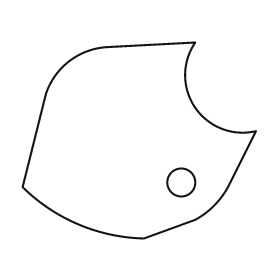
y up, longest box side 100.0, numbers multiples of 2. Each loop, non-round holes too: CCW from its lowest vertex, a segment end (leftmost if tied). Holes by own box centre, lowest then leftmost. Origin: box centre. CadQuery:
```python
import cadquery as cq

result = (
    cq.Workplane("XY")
    .moveTo(2.0, -42.0)
    .lineTo(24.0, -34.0)
    .threePointArc((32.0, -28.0), (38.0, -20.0))
    .lineTo(50.0, 4.0)
    .threePointArc((24.0, 14.0), (24.0, 42.0))
    .lineTo(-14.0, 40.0)
    .threePointArc((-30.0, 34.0), (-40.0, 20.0))
    .lineTo(-50.0, -20.0)
    .threePointArc((-26.0, -36.0), (2.0, -42.0))
    .close()
    .moveTo(18.0, -18.0)
    .circle(6.0)
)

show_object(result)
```